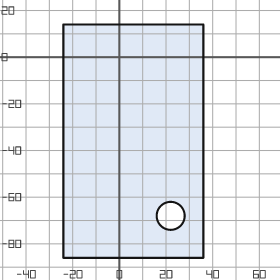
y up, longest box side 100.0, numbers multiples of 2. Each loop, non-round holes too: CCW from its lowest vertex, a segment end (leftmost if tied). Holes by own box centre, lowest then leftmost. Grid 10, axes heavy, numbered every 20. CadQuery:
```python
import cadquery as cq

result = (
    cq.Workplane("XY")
    .moveTo(-24.0, -86.0)
    .lineTo(36.0, -86.0)
    .lineTo(36.0, 14.0)
    .lineTo(-24.0, 14.0)
    .close()
    .moveTo(22.0, -68.0)
    .circle(6.0)
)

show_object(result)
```